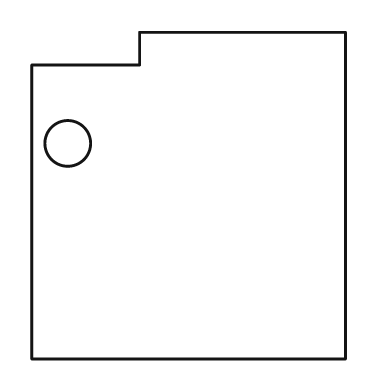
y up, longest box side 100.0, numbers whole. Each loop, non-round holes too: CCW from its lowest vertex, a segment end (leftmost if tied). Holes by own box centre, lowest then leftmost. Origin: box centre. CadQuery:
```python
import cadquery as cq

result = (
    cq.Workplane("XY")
    .moveTo(-48.0, -50.0)
    .lineTo(48.0, -50.0)
    .lineTo(48.0, 50.0)
    .lineTo(-15.0, 50.0)
    .lineTo(-15.0, 40.0)
    .lineTo(-48.0, 40.0)
    .close()
    .moveTo(-37.0, 16.0)
    .circle(7.0)
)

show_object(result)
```